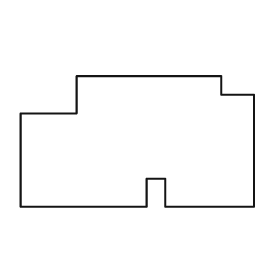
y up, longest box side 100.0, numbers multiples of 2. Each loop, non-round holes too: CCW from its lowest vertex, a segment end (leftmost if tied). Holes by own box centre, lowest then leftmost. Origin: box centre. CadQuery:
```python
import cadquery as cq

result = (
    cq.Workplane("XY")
    .moveTo(-50.0, -28.0)
    .lineTo(4.0, -28.0)
    .lineTo(4.0, -16.0)
    .lineTo(12.0, -16.0)
    .lineTo(12.0, -28.0)
    .lineTo(50.0, -28.0)
    .lineTo(50.0, 20.0)
    .lineTo(36.0, 20.0)
    .lineTo(36.0, 28.0)
    .lineTo(-26.0, 28.0)
    .lineTo(-26.0, 12.0)
    .lineTo(-50.0, 12.0)
    .close()
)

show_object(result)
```